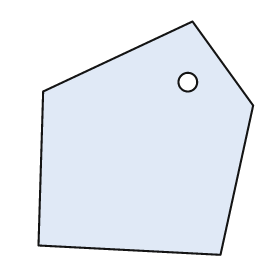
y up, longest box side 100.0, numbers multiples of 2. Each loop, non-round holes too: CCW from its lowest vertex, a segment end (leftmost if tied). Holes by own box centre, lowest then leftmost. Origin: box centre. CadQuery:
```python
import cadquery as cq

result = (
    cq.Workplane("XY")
    .moveTo(32.0, -50.0)
    .lineTo(46.0, 14.0)
    .lineTo(20.0, 50.0)
    .lineTo(-44.0, 20.0)
    .lineTo(-46.0, -46.0)
    .close()
    .moveTo(18.0, 24.0)
    .circle(4.0)
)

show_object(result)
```